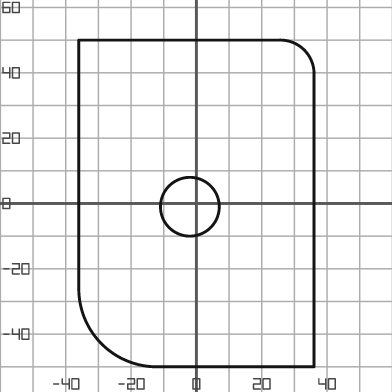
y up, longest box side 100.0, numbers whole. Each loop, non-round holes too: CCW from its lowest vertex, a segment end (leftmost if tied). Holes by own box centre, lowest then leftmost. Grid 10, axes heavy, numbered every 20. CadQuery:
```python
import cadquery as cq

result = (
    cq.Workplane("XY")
    .moveTo(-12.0, -50.0)
    .lineTo(36.0, -50.0)
    .lineTo(36.0, 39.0)
    .threePointArc((33.0, 47.0), (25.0, 50.0))
    .lineTo(-36.0, 50.0)
    .lineTo(-36.0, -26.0)
    .threePointArc((-29.0, -43.0), (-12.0, -50.0))
    .close()
    .moveTo(-2.0, -1.0)
    .circle(9.0)
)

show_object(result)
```